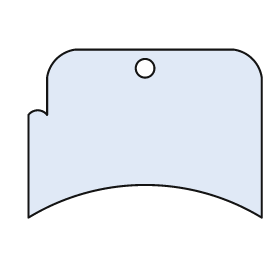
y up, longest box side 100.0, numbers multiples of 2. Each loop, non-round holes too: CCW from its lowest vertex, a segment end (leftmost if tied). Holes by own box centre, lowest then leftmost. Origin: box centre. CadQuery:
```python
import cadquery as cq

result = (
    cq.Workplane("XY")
    .moveTo(-50.0, -36.0)
    .threePointArc((0.0, -22.0), (50.0, -36.0))
    .lineTo(50.0, 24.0)
    .threePointArc((46.0, 32.0), (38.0, 36.0))
    .lineTo(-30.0, 36.0)
    .threePointArc((-38.0, 32.0), (-42.0, 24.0))
    .lineTo(-42.0, 8.0)
    .threePointArc((-46.0, 10.0), (-50.0, 8.0))
    .close()
    .moveTo(0.0, 28.0)
    .circle(4.0)
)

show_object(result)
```